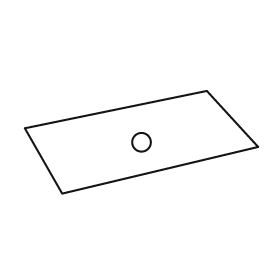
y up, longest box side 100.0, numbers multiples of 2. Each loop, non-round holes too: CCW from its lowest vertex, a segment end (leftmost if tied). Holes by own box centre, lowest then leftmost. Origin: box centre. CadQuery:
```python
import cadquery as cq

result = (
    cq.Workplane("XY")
    .moveTo(-34.0, -22.0)
    .lineTo(50.0, -2.0)
    .lineTo(28.0, 22.0)
    .lineTo(-50.0, 6.0)
    .close()
    .moveTo(0.0, 0.0)
    .circle(4.0)
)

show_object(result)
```